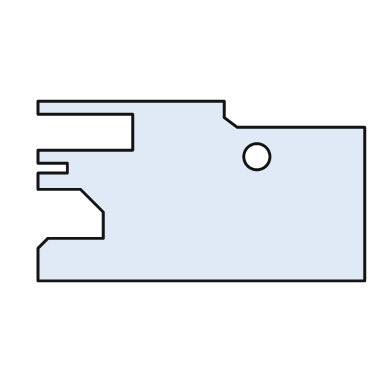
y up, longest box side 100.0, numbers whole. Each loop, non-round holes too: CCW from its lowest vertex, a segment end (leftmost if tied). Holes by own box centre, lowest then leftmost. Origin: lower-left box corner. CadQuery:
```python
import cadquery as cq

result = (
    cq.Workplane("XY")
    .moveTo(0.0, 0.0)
    .lineTo(100.0, 0.0)
    .lineTo(100.0, 47.0)
    .lineTo(61.0, 47.0)
    .lineTo(57.0, 50.0)
    .lineTo(57.0, 55.0)
    .lineTo(0.0, 55.0)
    .lineTo(0.0, 51.0)
    .lineTo(29.0, 51.0)
    .lineTo(29.0, 40.0)
    .lineTo(0.0, 40.0)
    .lineTo(0.0, 36.0)
    .lineTo(9.0, 36.0)
    .lineTo(9.0, 33.0)
    .lineTo(0.0, 33.0)
    .lineTo(0.0, 28.0)
    .lineTo(13.0, 28.0)
    .lineTo(20.0, 21.0)
    .lineTo(20.0, 13.0)
    .lineTo(3.0, 13.0)
    .lineTo(0.0, 10.0)
    .close()
    .moveTo(67.0, 38.0)
    .circle(4.0)
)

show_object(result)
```